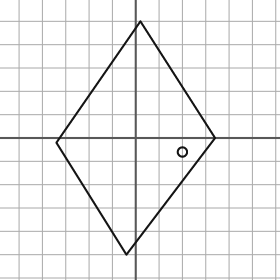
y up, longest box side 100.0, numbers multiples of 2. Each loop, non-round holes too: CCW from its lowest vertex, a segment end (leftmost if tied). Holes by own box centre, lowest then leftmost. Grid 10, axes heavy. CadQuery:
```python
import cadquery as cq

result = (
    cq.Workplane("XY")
    .moveTo(-4.0, -50.0)
    .lineTo(34.0, 0.0)
    .lineTo(2.0, 50.0)
    .lineTo(-34.0, -2.0)
    .close()
    .moveTo(20.0, -6.0)
    .circle(2.0)
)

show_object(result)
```